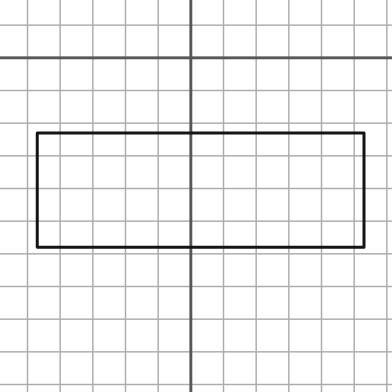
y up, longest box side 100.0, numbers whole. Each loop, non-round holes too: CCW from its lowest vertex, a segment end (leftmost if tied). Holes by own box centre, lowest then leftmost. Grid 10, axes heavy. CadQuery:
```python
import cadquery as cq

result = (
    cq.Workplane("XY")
    .moveTo(-47.0, -58.0)
    .lineTo(53.0, -58.0)
    .lineTo(53.0, -23.0)
    .lineTo(-47.0, -23.0)
    .close()
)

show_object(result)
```